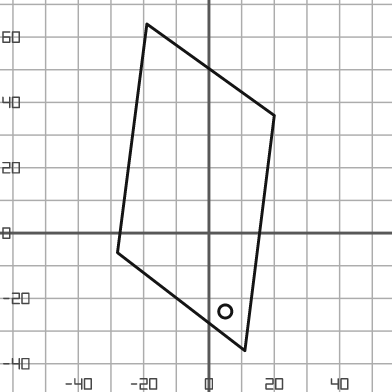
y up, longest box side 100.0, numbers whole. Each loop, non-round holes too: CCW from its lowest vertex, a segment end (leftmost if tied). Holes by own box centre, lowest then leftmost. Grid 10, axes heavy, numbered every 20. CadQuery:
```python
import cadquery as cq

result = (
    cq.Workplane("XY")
    .moveTo(11.0, -36.0)
    .lineTo(20.0, 36.0)
    .lineTo(-19.0, 64.0)
    .lineTo(-28.0, -6.0)
    .close()
    .moveTo(5.0, -24.0)
    .circle(2.0)
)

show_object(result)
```